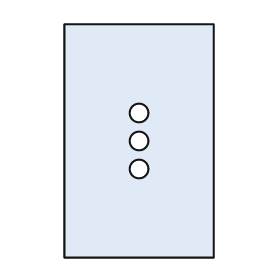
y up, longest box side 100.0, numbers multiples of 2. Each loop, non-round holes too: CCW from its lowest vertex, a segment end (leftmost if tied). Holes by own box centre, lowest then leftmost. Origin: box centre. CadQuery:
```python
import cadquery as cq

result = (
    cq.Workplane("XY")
    .moveTo(-32.0, -50.0)
    .lineTo(32.0, -50.0)
    .lineTo(32.0, 50.0)
    .lineTo(-32.0, 50.0)
    .close()
    .moveTo(0.0, -12.0)
    .circle(4.0)
    .moveTo(0.0, 0.0)
    .circle(4.0)
    .moveTo(0.0, 12.0)
    .circle(4.0)
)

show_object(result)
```